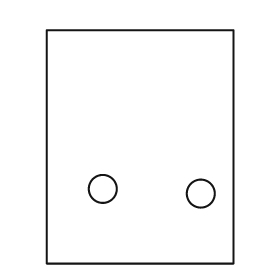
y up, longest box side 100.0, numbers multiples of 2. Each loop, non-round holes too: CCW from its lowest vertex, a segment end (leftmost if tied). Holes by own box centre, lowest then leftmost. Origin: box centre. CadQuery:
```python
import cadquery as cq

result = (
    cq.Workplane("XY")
    .moveTo(-40.0, -50.0)
    .lineTo(40.0, -50.0)
    .lineTo(40.0, 50.0)
    .lineTo(-40.0, 50.0)
    .close()
    .moveTo(26.0, -20.0)
    .circle(6.0)
    .moveTo(-16.0, -18.0)
    .circle(6.0)
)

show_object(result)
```